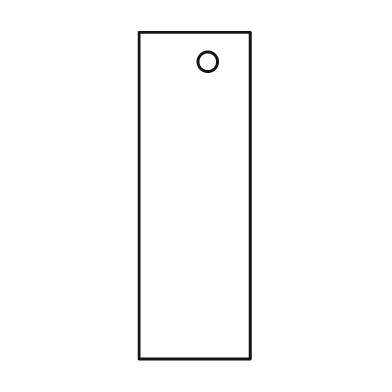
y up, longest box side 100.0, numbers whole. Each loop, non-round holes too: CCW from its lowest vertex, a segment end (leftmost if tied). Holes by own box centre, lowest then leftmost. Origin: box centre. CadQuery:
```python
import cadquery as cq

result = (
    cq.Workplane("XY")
    .moveTo(-17.0, -50.0)
    .lineTo(17.0, -50.0)
    .lineTo(17.0, 50.0)
    .lineTo(-17.0, 50.0)
    .close()
    .moveTo(4.0, 41.0)
    .circle(3.0)
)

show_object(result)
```